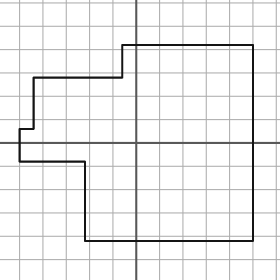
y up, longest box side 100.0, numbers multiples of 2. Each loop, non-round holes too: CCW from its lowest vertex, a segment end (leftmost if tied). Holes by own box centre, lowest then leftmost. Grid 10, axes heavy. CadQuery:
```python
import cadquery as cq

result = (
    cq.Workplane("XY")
    .moveTo(-22.0, -42.0)
    .lineTo(50.0, -42.0)
    .lineTo(50.0, 42.0)
    .lineTo(-6.0, 42.0)
    .lineTo(-6.0, 28.0)
    .lineTo(-44.0, 28.0)
    .lineTo(-44.0, 6.0)
    .lineTo(-50.0, 6.0)
    .lineTo(-50.0, -8.0)
    .lineTo(-22.0, -8.0)
    .close()
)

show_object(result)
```